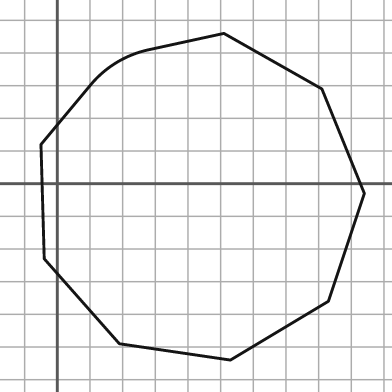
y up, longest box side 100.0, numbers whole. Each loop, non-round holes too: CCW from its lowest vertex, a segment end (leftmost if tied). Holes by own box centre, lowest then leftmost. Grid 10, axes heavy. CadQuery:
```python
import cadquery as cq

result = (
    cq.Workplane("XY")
    .moveTo(53.0, -54.0)
    .lineTo(83.0, -36.0)
    .lineTo(94.0, -3.0)
    .lineTo(81.0, 29.0)
    .lineTo(51.0, 46.0)
    .lineTo(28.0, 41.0)
    .threePointArc((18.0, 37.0), (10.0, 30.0))
    .lineTo(-5.0, 12.0)
    .lineTo(-4.0, -23.0)
    .lineTo(19.0, -49.0)
    .close()
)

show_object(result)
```